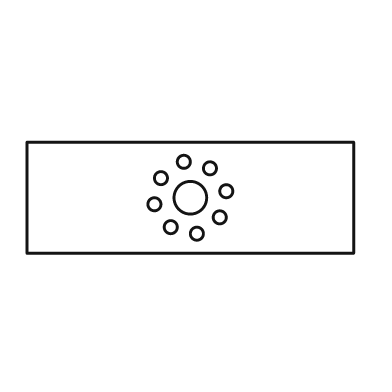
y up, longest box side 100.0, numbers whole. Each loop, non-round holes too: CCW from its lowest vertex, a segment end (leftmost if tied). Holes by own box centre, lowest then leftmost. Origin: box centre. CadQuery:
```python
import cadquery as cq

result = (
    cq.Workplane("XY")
    .moveTo(-50.0, -17.0)
    .lineTo(50.0, -17.0)
    .lineTo(50.0, 17.0)
    .lineTo(-50.0, 17.0)
    .close()
    .moveTo(2.0, -11.0)
    .circle(2.0)
    .moveTo(-6.0, -9.0)
    .circle(2.0)
    .moveTo(9.0, -6.0)
    .circle(2.0)
    .moveTo(-11.0, -2.0)
    .circle(2.0)
    .moveTo(0.0, 0.0)
    .circle(5.0)
    .moveTo(11.0, 2.0)
    .circle(2.0)
    .moveTo(-9.0, 6.0)
    .circle(2.0)
    .moveTo(6.0, 9.0)
    .circle(2.0)
    .moveTo(-2.0, 11.0)
    .circle(2.0)
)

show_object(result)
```